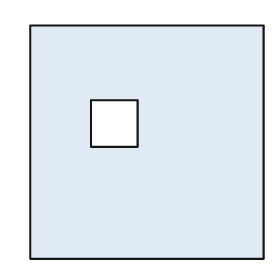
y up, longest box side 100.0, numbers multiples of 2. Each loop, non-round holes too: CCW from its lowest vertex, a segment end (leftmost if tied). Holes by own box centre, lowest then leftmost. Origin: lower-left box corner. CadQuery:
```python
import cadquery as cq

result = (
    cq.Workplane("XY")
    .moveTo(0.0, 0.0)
    .lineTo(100.0, 0.0)
    .lineTo(100.0, 100.0)
    .lineTo(0.0, 100.0)
    .close()
    .moveTo(26.0, 48.0)
    .lineTo(46.0, 48.0)
    .lineTo(46.0, 68.0)
    .lineTo(26.0, 68.0)
    .close()
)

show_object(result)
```